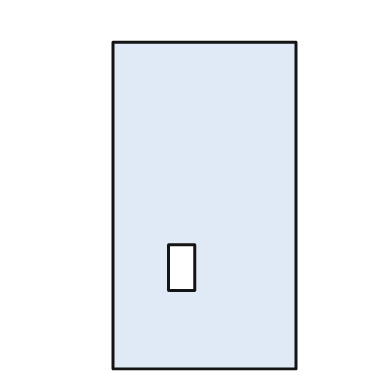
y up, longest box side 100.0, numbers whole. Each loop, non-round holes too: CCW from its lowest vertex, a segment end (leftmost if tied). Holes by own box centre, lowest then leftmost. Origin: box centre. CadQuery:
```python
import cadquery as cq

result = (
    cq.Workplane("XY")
    .moveTo(-28.0, -50.0)
    .lineTo(28.0, -50.0)
    .lineTo(28.0, 50.0)
    .lineTo(-28.0, 50.0)
    .close()
    .moveTo(-11.0, -26.0)
    .lineTo(-3.0, -26.0)
    .lineTo(-3.0, -12.0)
    .lineTo(-11.0, -12.0)
    .close()
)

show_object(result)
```